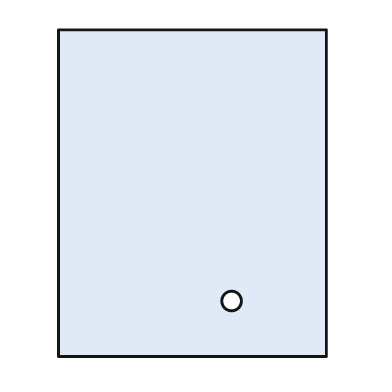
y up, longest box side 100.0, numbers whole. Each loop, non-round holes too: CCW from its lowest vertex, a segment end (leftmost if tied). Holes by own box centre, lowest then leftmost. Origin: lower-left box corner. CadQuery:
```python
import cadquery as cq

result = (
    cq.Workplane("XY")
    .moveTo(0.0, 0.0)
    .lineTo(82.0, 0.0)
    .lineTo(82.0, 100.0)
    .lineTo(0.0, 100.0)
    .close()
    .moveTo(53.0, 17.0)
    .circle(3.0)
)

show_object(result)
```